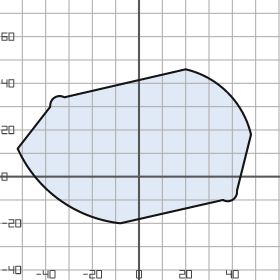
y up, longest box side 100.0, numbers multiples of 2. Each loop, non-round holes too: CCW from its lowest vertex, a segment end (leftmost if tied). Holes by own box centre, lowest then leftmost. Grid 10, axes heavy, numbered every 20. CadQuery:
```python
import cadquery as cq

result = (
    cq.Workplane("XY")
    .moveTo(-8.0, -20.0)
    .lineTo(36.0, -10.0)
    .threePointArc((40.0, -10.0), (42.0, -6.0))
    .lineTo(48.0, 18.0)
    .threePointArc((38.0, 36.0), (20.0, 46.0))
    .lineTo(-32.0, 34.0)
    .threePointArc((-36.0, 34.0), (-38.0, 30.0))
    .lineTo(-52.0, 12.0)
    .threePointArc((-34.0, -10.0), (-8.0, -20.0))
    .close()
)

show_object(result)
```